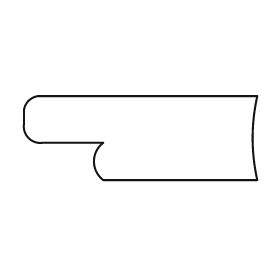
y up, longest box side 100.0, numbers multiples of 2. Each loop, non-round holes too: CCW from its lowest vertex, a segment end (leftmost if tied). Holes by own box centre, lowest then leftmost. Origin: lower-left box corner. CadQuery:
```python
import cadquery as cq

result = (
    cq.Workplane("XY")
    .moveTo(34.0, 0.0)
    .lineTo(100.0, 0.0)
    .threePointArc((98.0, 18.0), (100.0, 36.0))
    .lineTo(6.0, 36.0)
    .threePointArc((2.0, 34.0), (0.0, 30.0))
    .lineTo(0.0, 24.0)
    .threePointArc((2.0, 18.0), (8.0, 16.0))
    .lineTo(34.0, 16.0)
    .threePointArc((30.0, 8.0), (34.0, 0.0))
    .close()
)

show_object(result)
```